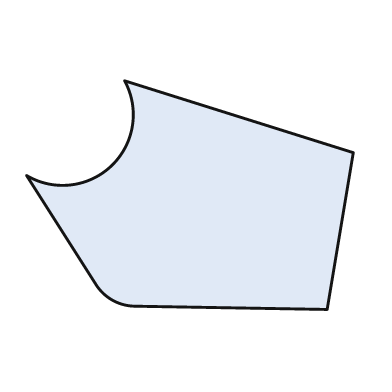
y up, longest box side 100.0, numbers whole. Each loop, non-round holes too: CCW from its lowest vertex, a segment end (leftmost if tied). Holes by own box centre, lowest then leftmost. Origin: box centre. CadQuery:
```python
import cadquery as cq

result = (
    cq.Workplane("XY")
    .moveTo(42.0, -35.0)
    .lineTo(50.0, 13.0)
    .lineTo(-20.0, 35.0)
    .threePointArc((-24.0, 9.0), (-50.0, 6.0))
    .lineTo(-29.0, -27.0)
    .threePointArc((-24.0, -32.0), (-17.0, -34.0))
    .close()
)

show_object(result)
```